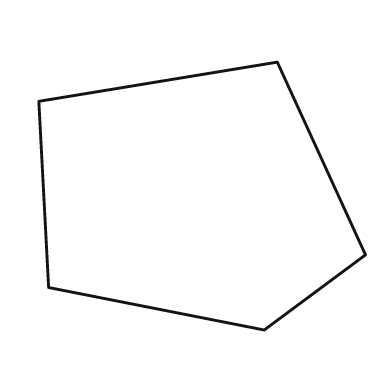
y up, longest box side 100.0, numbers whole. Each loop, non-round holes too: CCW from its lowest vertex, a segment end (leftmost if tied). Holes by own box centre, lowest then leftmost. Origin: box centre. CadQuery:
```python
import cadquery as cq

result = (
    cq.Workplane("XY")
    .moveTo(19.0, -41.0)
    .lineTo(50.0, -18.0)
    .lineTo(23.0, 41.0)
    .lineTo(-50.0, 29.0)
    .lineTo(-47.0, -28.0)
    .close()
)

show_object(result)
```